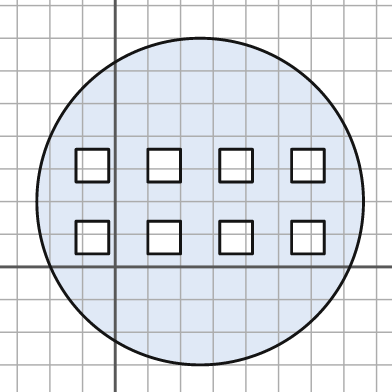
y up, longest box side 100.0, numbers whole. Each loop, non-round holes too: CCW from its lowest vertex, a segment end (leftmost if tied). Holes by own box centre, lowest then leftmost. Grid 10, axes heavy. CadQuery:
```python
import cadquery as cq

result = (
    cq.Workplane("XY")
    .moveTo(26.0, 20.0)
    .circle(50.0)
    .moveTo(-12.0, 4.0)
    .lineTo(-2.0, 4.0)
    .lineTo(-2.0, 14.0)
    .lineTo(-12.0, 14.0)
    .close()
    .moveTo(10.0, 4.0)
    .lineTo(20.0, 4.0)
    .lineTo(20.0, 14.0)
    .lineTo(10.0, 14.0)
    .close()
    .moveTo(32.0, 4.0)
    .lineTo(42.0, 4.0)
    .lineTo(42.0, 14.0)
    .lineTo(32.0, 14.0)
    .close()
    .moveTo(54.0, 4.0)
    .lineTo(64.0, 4.0)
    .lineTo(64.0, 14.0)
    .lineTo(54.0, 14.0)
    .close()
    .moveTo(-12.0, 26.0)
    .lineTo(-2.0, 26.0)
    .lineTo(-2.0, 36.0)
    .lineTo(-12.0, 36.0)
    .close()
    .moveTo(10.0, 26.0)
    .lineTo(20.0, 26.0)
    .lineTo(20.0, 36.0)
    .lineTo(10.0, 36.0)
    .close()
    .moveTo(32.0, 26.0)
    .lineTo(42.0, 26.0)
    .lineTo(42.0, 36.0)
    .lineTo(32.0, 36.0)
    .close()
    .moveTo(54.0, 26.0)
    .lineTo(64.0, 26.0)
    .lineTo(64.0, 36.0)
    .lineTo(54.0, 36.0)
    .close()
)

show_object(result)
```